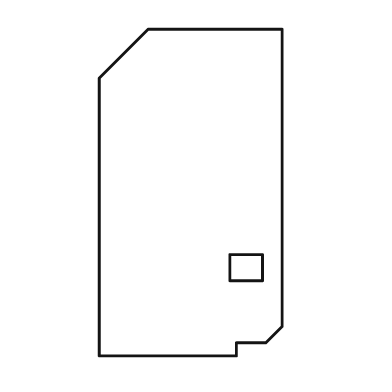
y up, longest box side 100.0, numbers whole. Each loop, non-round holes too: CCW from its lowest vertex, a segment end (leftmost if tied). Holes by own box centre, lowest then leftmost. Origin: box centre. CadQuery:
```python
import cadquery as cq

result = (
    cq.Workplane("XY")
    .moveTo(-28.0, -50.0)
    .lineTo(14.0, -50.0)
    .lineTo(14.0, -46.0)
    .lineTo(23.0, -46.0)
    .lineTo(28.0, -41.0)
    .lineTo(28.0, 50.0)
    .lineTo(-13.0, 50.0)
    .lineTo(-28.0, 35.0)
    .close()
    .moveTo(12.0, -27.0)
    .lineTo(22.0, -27.0)
    .lineTo(22.0, -19.0)
    .lineTo(12.0, -19.0)
    .close()
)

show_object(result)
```